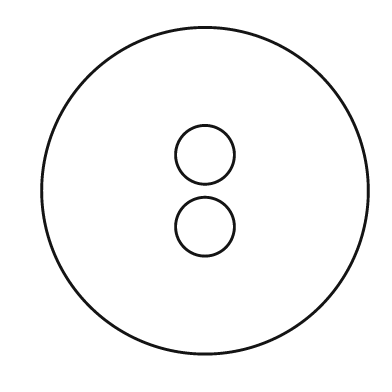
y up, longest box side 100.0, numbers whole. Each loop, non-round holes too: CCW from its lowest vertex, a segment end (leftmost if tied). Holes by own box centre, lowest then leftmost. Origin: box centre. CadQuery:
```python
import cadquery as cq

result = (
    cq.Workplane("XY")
    .moveTo(0.0, 0.0)
    .circle(50.0)
    .moveTo(0.0, -11.0)
    .circle(9.0)
    .moveTo(0.0, 11.0)
    .circle(9.0)
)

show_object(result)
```